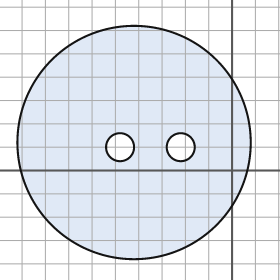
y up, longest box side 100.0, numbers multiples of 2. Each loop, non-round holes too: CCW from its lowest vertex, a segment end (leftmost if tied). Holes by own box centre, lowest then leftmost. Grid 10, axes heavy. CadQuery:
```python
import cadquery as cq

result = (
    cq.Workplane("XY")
    .moveTo(-42.0, 12.0)
    .circle(50.0)
    .moveTo(-48.0, 10.0)
    .circle(6.0)
    .moveTo(-22.0, 10.0)
    .circle(6.0)
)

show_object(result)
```